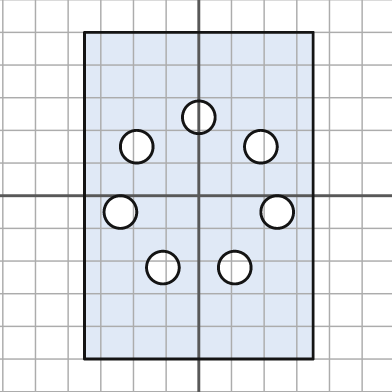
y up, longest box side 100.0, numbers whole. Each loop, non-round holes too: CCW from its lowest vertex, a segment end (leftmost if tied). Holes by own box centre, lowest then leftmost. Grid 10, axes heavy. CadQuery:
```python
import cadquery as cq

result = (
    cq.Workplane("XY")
    .moveTo(-35.0, -50.0)
    .lineTo(35.0, -50.0)
    .lineTo(35.0, 50.0)
    .lineTo(-35.0, 50.0)
    .close()
    .moveTo(-11.0, -22.0)
    .circle(5.0)
    .moveTo(11.0, -22.0)
    .circle(5.0)
    .moveTo(-24.0, -5.0)
    .circle(5.0)
    .moveTo(24.0, -5.0)
    .circle(5.0)
    .moveTo(-19.0, 15.0)
    .circle(5.0)
    .moveTo(19.0, 15.0)
    .circle(5.0)
    .moveTo(0.0, 24.0)
    .circle(5.0)
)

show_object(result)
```